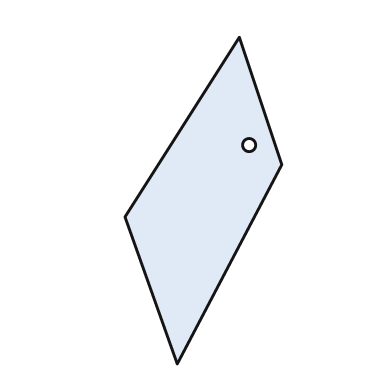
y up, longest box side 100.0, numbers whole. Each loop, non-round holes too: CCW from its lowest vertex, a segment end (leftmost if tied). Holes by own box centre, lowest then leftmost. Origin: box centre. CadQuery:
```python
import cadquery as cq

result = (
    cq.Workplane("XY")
    .moveTo(-8.0, -50.0)
    .lineTo(24.0, 11.0)
    .lineTo(11.0, 50.0)
    .lineTo(-24.0, -5.0)
    .close()
    .moveTo(14.0, 17.0)
    .circle(2.0)
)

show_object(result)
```